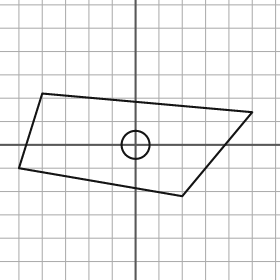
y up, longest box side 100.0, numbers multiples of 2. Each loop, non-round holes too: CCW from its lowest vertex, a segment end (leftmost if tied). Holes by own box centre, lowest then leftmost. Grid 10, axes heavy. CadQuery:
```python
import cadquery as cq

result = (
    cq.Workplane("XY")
    .moveTo(20.0, -22.0)
    .lineTo(50.0, 14.0)
    .lineTo(-40.0, 22.0)
    .lineTo(-50.0, -10.0)
    .close()
    .moveTo(0.0, 0.0)
    .circle(6.0)
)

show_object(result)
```